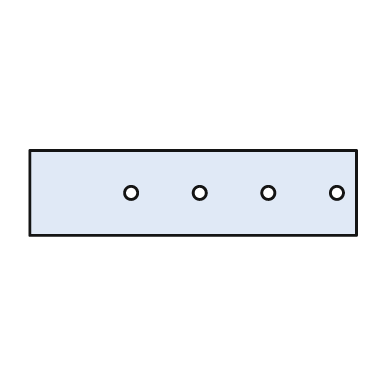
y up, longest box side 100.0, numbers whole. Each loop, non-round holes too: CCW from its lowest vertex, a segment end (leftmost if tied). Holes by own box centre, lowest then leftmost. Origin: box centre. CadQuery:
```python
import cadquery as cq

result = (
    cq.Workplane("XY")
    .moveTo(-50.0, -13.0)
    .lineTo(50.0, -13.0)
    .lineTo(50.0, 13.0)
    .lineTo(-50.0, 13.0)
    .close()
    .moveTo(-19.0, 0.0)
    .circle(2.0)
    .moveTo(2.0, 0.0)
    .circle(2.0)
    .moveTo(23.0, 0.0)
    .circle(2.0)
    .moveTo(44.0, 0.0)
    .circle(2.0)
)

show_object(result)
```